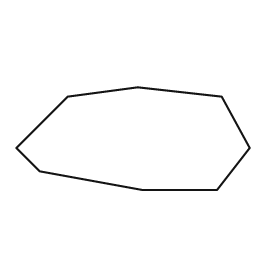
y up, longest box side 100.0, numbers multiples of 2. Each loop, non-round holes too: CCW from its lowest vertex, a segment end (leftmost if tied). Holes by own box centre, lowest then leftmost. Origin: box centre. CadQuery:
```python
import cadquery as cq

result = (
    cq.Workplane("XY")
    .moveTo(4.0, -22.0)
    .lineTo(36.0, -22.0)
    .lineTo(50.0, -4.0)
    .lineTo(38.0, 18.0)
    .lineTo(2.0, 22.0)
    .lineTo(-28.0, 18.0)
    .lineTo(-50.0, -4.0)
    .lineTo(-40.0, -14.0)
    .close()
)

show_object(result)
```